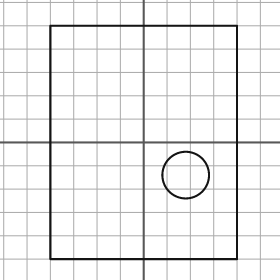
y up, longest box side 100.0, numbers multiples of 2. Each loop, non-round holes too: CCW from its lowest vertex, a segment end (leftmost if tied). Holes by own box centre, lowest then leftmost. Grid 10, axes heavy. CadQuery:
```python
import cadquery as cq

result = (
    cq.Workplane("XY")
    .moveTo(-40.0, -50.0)
    .lineTo(40.0, -50.0)
    .lineTo(40.0, 50.0)
    .lineTo(-40.0, 50.0)
    .close()
    .moveTo(18.0, -14.0)
    .circle(10.0)
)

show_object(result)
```